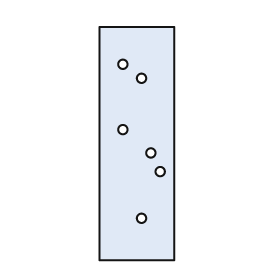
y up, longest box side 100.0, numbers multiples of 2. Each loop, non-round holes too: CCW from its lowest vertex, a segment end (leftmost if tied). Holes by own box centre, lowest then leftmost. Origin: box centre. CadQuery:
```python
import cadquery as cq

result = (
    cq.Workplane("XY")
    .moveTo(-16.0, -50.0)
    .lineTo(16.0, -50.0)
    .lineTo(16.0, 50.0)
    .lineTo(-16.0, 50.0)
    .close()
    .moveTo(2.0, -32.0)
    .circle(2.0)
    .moveTo(10.0, -12.0)
    .circle(2.0)
    .moveTo(6.0, -4.0)
    .circle(2.0)
    .moveTo(-6.0, 6.0)
    .circle(2.0)
    .moveTo(2.0, 28.0)
    .circle(2.0)
    .moveTo(-6.0, 34.0)
    .circle(2.0)
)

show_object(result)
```